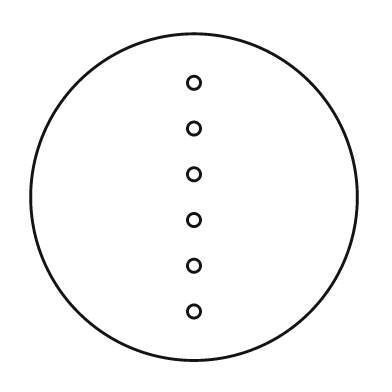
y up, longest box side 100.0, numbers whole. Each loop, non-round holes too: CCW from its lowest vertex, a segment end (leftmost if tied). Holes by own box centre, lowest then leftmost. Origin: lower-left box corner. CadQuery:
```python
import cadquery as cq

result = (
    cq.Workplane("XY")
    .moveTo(50.0, 50.0)
    .circle(50.0)
    .moveTo(50.0, 15.0)
    .circle(2.0)
    .moveTo(50.0, 29.0)
    .circle(2.0)
    .moveTo(50.0, 43.0)
    .circle(2.0)
    .moveTo(50.0, 57.0)
    .circle(2.0)
    .moveTo(50.0, 71.0)
    .circle(2.0)
    .moveTo(50.0, 85.0)
    .circle(2.0)
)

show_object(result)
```